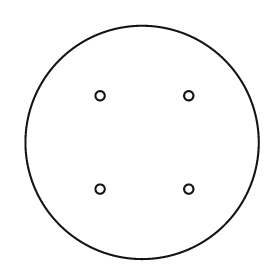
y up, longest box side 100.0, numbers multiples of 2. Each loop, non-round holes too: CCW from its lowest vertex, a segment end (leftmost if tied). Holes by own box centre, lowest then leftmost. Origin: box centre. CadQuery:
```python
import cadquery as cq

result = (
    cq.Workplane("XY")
    .moveTo(0.0, 0.0)
    .circle(50.0)
    .moveTo(-18.0, -20.0)
    .circle(2.0)
    .moveTo(20.0, -20.0)
    .circle(2.0)
    .moveTo(-18.0, 20.0)
    .circle(2.0)
    .moveTo(20.0, 20.0)
    .circle(2.0)
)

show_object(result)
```